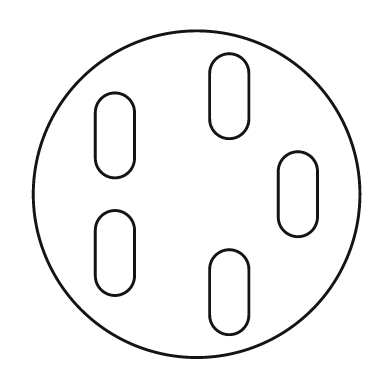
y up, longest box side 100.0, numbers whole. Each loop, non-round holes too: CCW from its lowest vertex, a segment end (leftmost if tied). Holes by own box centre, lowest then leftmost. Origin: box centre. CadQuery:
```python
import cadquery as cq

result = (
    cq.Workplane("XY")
    .moveTo(0.0, 0.0)
    .circle(50.0)
    .moveTo(4.0, -37.0)
    .threePointArc((10.0, -43.0), (16.0, -37.0))
    .lineTo(16.0, -23.0)
    .threePointArc((10.0, -17.0), (4.0, -23.0))
    .close()
    .moveTo(-31.0, -25.0)
    .threePointArc((-25.0, -31.0), (-19.0, -25.0))
    .lineTo(-19.0, -11.0)
    .threePointArc((-25.0, -5.0), (-31.0, -11.0))
    .close()
    .moveTo(25.0, -7.0)
    .threePointArc((31.0, -13.0), (37.0, -7.0))
    .lineTo(37.0, 7.0)
    .threePointArc((31.0, 13.0), (25.0, 7.0))
    .close()
    .moveTo(-31.0, 11.0)
    .threePointArc((-25.0, 5.0), (-19.0, 11.0))
    .lineTo(-19.0, 25.0)
    .threePointArc((-25.0, 31.0), (-31.0, 25.0))
    .close()
    .moveTo(4.0, 23.0)
    .threePointArc((10.0, 17.0), (16.0, 23.0))
    .lineTo(16.0, 37.0)
    .threePointArc((10.0, 43.0), (4.0, 37.0))
    .close()
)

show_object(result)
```